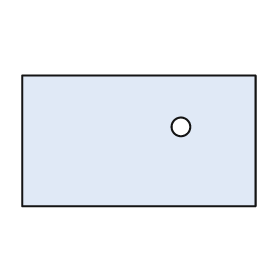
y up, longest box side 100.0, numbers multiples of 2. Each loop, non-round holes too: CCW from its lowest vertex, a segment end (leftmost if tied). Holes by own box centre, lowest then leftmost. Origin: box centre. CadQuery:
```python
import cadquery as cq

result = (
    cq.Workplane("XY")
    .moveTo(-50.0, -28.0)
    .lineTo(50.0, -28.0)
    .lineTo(50.0, 28.0)
    .lineTo(-50.0, 28.0)
    .close()
    .moveTo(18.0, 6.0)
    .circle(4.0)
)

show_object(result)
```